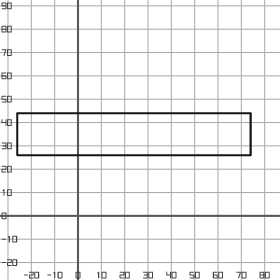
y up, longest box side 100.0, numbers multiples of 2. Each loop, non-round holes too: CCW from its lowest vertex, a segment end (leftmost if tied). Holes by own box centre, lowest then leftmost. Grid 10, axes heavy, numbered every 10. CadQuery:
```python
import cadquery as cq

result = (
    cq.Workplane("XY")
    .moveTo(-26.0, 26.0)
    .lineTo(74.0, 26.0)
    .lineTo(74.0, 44.0)
    .lineTo(-26.0, 44.0)
    .close()
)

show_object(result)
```